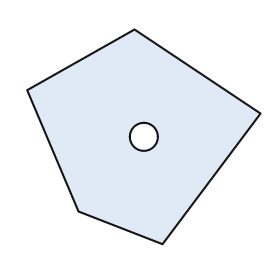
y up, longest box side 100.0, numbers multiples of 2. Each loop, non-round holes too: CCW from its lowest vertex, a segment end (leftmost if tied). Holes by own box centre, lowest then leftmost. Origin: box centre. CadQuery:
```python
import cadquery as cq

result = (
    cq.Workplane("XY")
    .moveTo(8.0, -46.0)
    .lineTo(50.0, 10.0)
    .lineTo(-4.0, 46.0)
    .lineTo(-50.0, 20.0)
    .lineTo(-28.0, -32.0)
    .close()
    .moveTo(0.0, 0.0)
    .circle(6.0)
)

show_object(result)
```